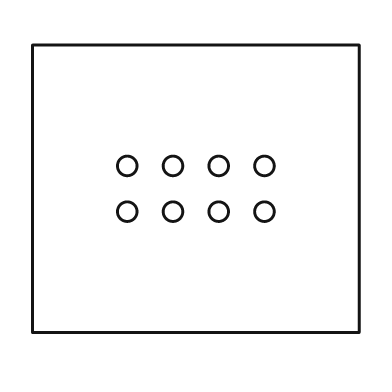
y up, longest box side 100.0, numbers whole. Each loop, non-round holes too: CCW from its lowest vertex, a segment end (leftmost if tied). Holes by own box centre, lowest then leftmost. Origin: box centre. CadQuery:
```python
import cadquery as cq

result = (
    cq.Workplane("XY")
    .moveTo(-50.0, -44.0)
    .lineTo(50.0, -44.0)
    .lineTo(50.0, 44.0)
    .lineTo(-50.0, 44.0)
    .close()
    .moveTo(-21.0, -7.0)
    .circle(3.0)
    .moveTo(-7.0, -7.0)
    .circle(3.0)
    .moveTo(7.0, -7.0)
    .circle(3.0)
    .moveTo(21.0, -7.0)
    .circle(3.0)
    .moveTo(-21.0, 7.0)
    .circle(3.0)
    .moveTo(-7.0, 7.0)
    .circle(3.0)
    .moveTo(7.0, 7.0)
    .circle(3.0)
    .moveTo(21.0, 7.0)
    .circle(3.0)
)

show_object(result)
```